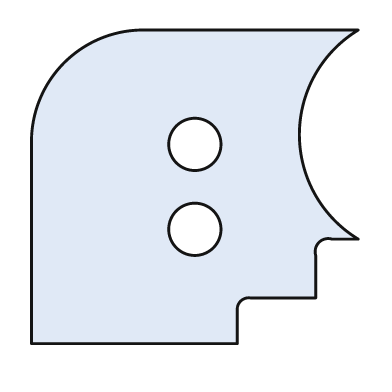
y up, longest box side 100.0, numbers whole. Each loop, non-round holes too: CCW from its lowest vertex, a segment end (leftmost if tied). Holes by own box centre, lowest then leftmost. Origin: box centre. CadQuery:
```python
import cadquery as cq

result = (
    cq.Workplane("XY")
    .moveTo(-50.0, -48.0)
    .lineTo(13.0, -48.0)
    .lineTo(13.0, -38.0)
    .threePointArc((14.0, -35.0), (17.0, -34.0))
    .lineTo(37.0, -34.0)
    .lineTo(37.0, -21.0)
    .threePointArc((38.0, -17.0), (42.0, -16.0))
    .lineTo(50.0, -16.0)
    .threePointArc((32.0, 16.0), (50.0, 48.0))
    .lineTo(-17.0, 48.0)
    .threePointArc((-40.0, 38.0), (-50.0, 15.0))
    .close()
    .moveTo(0.0, -13.0)
    .circle(8.0)
    .moveTo(0.0, 13.0)
    .circle(8.0)
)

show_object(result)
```